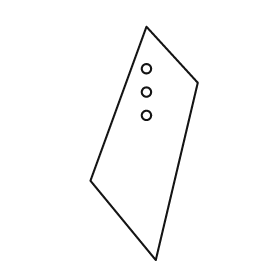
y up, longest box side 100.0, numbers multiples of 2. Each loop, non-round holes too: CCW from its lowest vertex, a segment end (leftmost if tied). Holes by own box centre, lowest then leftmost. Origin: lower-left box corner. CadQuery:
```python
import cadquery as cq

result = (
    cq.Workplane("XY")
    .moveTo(28.0, 0.0)
    .lineTo(46.0, 76.0)
    .lineTo(24.0, 100.0)
    .lineTo(0.0, 34.0)
    .close()
    .moveTo(24.0, 62.0)
    .circle(2.0)
    .moveTo(24.0, 72.0)
    .circle(2.0)
    .moveTo(24.0, 82.0)
    .circle(2.0)
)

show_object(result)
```